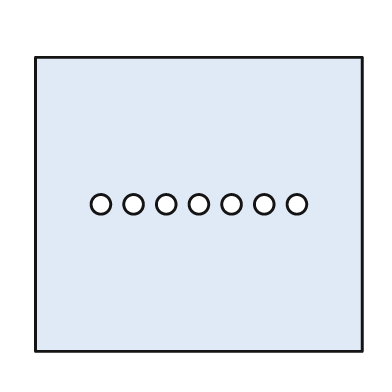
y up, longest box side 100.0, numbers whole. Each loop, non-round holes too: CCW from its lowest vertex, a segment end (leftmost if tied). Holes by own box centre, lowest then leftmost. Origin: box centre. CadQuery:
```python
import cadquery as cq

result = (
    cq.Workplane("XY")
    .moveTo(-50.0, -45.0)
    .lineTo(50.0, -45.0)
    .lineTo(50.0, 45.0)
    .lineTo(-50.0, 45.0)
    .close()
    .moveTo(-30.0, 0.0)
    .circle(3.0)
    .moveTo(-20.0, 0.0)
    .circle(3.0)
    .moveTo(-10.0, 0.0)
    .circle(3.0)
    .moveTo(0.0, 0.0)
    .circle(3.0)
    .moveTo(10.0, 0.0)
    .circle(3.0)
    .moveTo(20.0, 0.0)
    .circle(3.0)
    .moveTo(30.0, 0.0)
    .circle(3.0)
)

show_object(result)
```